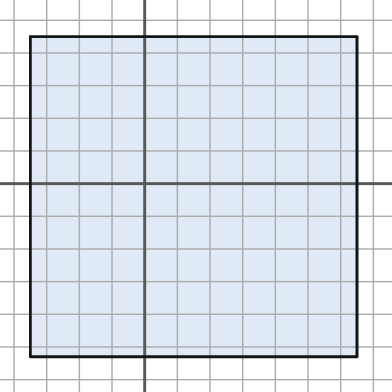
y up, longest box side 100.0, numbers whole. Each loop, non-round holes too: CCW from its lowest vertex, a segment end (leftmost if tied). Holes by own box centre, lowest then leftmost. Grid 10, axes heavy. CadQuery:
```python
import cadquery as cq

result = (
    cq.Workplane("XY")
    .moveTo(-35.0, -53.0)
    .lineTo(65.0, -53.0)
    .lineTo(65.0, 45.0)
    .lineTo(-35.0, 45.0)
    .close()
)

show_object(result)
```